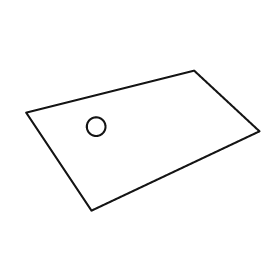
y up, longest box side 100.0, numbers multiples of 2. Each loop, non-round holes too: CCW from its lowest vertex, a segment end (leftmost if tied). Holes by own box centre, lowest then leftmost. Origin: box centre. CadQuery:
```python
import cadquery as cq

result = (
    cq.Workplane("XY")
    .moveTo(-22.0, -30.0)
    .lineTo(50.0, 4.0)
    .lineTo(22.0, 30.0)
    .lineTo(-50.0, 12.0)
    .close()
    .moveTo(-20.0, 6.0)
    .circle(4.0)
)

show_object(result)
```